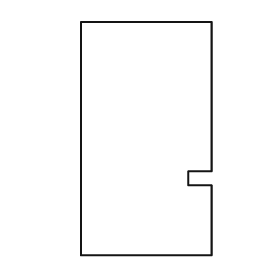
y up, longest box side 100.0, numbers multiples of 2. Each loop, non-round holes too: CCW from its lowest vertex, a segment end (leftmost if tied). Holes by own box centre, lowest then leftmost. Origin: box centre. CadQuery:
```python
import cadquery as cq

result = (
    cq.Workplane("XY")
    .moveTo(-28.0, -50.0)
    .lineTo(28.0, -50.0)
    .lineTo(28.0, -20.0)
    .lineTo(18.0, -20.0)
    .lineTo(18.0, -14.0)
    .lineTo(28.0, -14.0)
    .lineTo(28.0, 50.0)
    .lineTo(-28.0, 50.0)
    .close()
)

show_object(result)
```